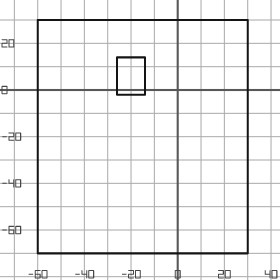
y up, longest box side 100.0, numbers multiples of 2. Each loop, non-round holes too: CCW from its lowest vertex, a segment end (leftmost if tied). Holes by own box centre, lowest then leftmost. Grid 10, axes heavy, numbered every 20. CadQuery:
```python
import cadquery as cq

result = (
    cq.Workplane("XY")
    .moveTo(-60.0, -70.0)
    .lineTo(30.0, -70.0)
    .lineTo(30.0, 30.0)
    .lineTo(-60.0, 30.0)
    .close()
    .moveTo(-26.0, -2.0)
    .lineTo(-14.0, -2.0)
    .lineTo(-14.0, 14.0)
    .lineTo(-26.0, 14.0)
    .close()
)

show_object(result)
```